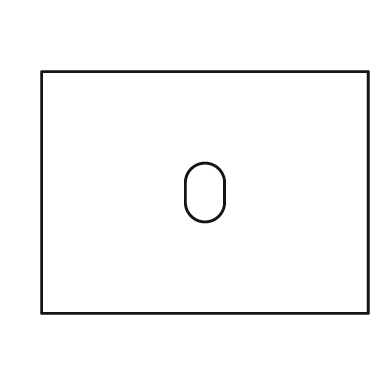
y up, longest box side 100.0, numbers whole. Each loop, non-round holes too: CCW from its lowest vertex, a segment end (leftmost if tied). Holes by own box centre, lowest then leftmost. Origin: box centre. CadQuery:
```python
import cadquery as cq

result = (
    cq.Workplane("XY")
    .moveTo(-50.0, -37.0)
    .lineTo(50.0, -37.0)
    .lineTo(50.0, 37.0)
    .lineTo(-50.0, 37.0)
    .close()
    .moveTo(-6.0, -3.0)
    .threePointArc((0.0, -9.0), (6.0, -3.0))
    .lineTo(6.0, 3.0)
    .threePointArc((0.0, 9.0), (-6.0, 3.0))
    .close()
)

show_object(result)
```